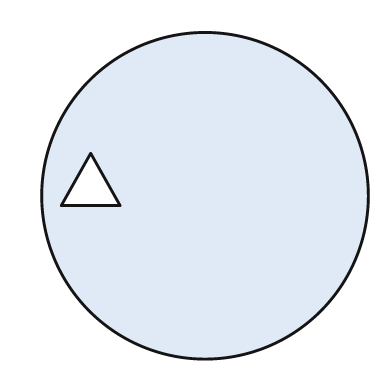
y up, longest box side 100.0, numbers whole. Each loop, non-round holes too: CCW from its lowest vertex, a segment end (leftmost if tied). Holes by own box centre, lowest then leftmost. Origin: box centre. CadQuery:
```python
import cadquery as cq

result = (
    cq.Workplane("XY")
    .moveTo(0.0, 0.0)
    .circle(50.0)
    .moveTo(-44.0, -3.0)
    .lineTo(-26.0, -3.0)
    .lineTo(-35.0, 13.0)
    .close()
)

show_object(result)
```